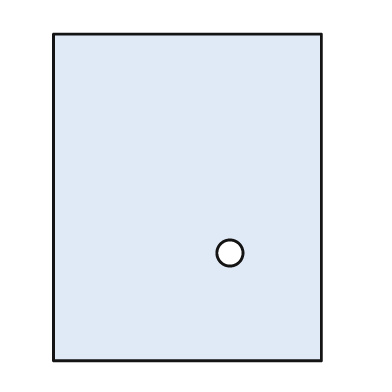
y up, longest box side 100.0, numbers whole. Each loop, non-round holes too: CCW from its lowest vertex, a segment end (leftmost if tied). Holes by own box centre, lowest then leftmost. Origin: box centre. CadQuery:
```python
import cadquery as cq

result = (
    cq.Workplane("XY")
    .moveTo(-41.0, -50.0)
    .lineTo(41.0, -50.0)
    .lineTo(41.0, 50.0)
    .lineTo(-41.0, 50.0)
    .close()
    .moveTo(13.0, -17.0)
    .circle(4.0)
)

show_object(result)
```